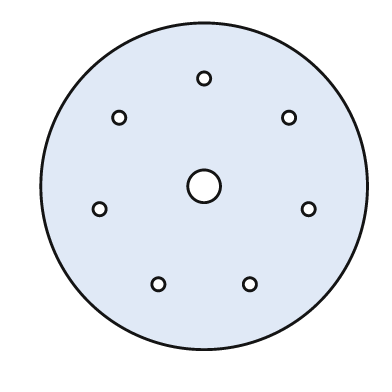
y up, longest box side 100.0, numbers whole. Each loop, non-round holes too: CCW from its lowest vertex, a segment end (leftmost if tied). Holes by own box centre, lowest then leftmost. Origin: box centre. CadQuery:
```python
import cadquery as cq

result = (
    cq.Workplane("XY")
    .moveTo(0.0, 0.0)
    .circle(50.0)
    .moveTo(-14.0, -30.0)
    .circle(2.0)
    .moveTo(14.0, -30.0)
    .circle(2.0)
    .moveTo(-32.0, -7.0)
    .circle(2.0)
    .moveTo(32.0, -7.0)
    .circle(2.0)
    .moveTo(0.0, 0.0)
    .circle(5.0)
    .moveTo(-26.0, 21.0)
    .circle(2.0)
    .moveTo(26.0, 21.0)
    .circle(2.0)
    .moveTo(0.0, 33.0)
    .circle(2.0)
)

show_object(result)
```